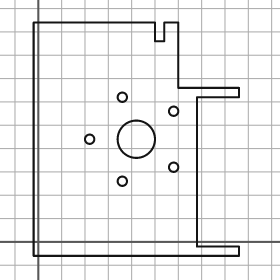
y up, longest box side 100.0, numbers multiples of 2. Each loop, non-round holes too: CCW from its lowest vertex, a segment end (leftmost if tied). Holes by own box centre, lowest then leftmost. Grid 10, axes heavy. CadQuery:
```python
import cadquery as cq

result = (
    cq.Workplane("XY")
    .moveTo(-2.0, -6.0)
    .lineTo(86.0, -6.0)
    .lineTo(86.0, -2.0)
    .lineTo(68.0, -2.0)
    .lineTo(68.0, 62.0)
    .lineTo(86.0, 62.0)
    .lineTo(86.0, 66.0)
    .lineTo(60.0, 66.0)
    .lineTo(60.0, 94.0)
    .lineTo(54.0, 94.0)
    .lineTo(54.0, 86.0)
    .lineTo(50.0, 86.0)
    .lineTo(50.0, 94.0)
    .lineTo(-2.0, 94.0)
    .close()
    .moveTo(36.0, 26.0)
    .circle(2.0)
    .moveTo(58.0, 32.0)
    .circle(2.0)
    .moveTo(22.0, 44.0)
    .circle(2.0)
    .moveTo(42.0, 44.0)
    .circle(8.0)
    .moveTo(58.0, 56.0)
    .circle(2.0)
    .moveTo(36.0, 62.0)
    .circle(2.0)
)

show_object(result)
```